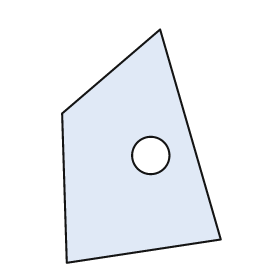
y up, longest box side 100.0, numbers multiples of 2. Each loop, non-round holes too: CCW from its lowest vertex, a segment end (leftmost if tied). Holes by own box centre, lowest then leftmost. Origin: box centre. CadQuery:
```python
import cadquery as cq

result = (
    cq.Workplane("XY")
    .moveTo(-32.0, -50.0)
    .lineTo(34.0, -40.0)
    .lineTo(8.0, 50.0)
    .lineTo(-34.0, 14.0)
    .close()
    .moveTo(4.0, -4.0)
    .circle(8.0)
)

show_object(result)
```